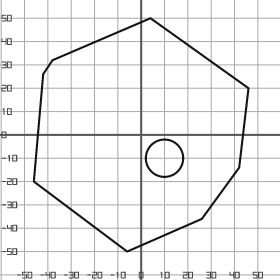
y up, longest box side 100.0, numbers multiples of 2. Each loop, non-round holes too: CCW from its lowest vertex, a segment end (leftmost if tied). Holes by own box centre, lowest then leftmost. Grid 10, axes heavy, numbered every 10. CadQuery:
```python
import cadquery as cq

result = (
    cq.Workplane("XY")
    .moveTo(-6.0, -50.0)
    .lineTo(26.0, -36.0)
    .lineTo(42.0, -14.0)
    .lineTo(46.0, 20.0)
    .lineTo(4.0, 50.0)
    .lineTo(-38.0, 32.0)
    .lineTo(-42.0, 26.0)
    .lineTo(-46.0, -20.0)
    .close()
    .moveTo(10.0, -10.0)
    .circle(8.0)
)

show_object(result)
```